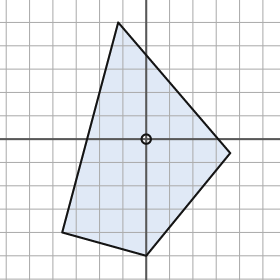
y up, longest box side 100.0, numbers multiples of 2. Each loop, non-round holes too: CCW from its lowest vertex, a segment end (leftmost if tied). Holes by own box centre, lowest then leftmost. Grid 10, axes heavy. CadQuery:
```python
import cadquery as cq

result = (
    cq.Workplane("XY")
    .moveTo(0.0, -50.0)
    .lineTo(36.0, -6.0)
    .lineTo(-12.0, 50.0)
    .lineTo(-36.0, -40.0)
    .close()
    .moveTo(0.0, 0.0)
    .circle(2.0)
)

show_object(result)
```